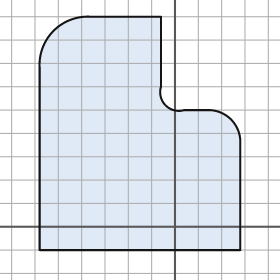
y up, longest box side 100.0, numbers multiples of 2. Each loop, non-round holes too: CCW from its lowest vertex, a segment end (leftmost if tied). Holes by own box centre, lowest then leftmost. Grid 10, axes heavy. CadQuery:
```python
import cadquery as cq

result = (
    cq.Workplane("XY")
    .moveTo(-58.0, -10.0)
    .lineTo(28.0, -10.0)
    .lineTo(28.0, 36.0)
    .threePointArc((24.0, 46.0), (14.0, 50.0))
    .lineTo(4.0, 50.0)
    .threePointArc((-4.0, 52.0), (-6.0, 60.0))
    .lineTo(-6.0, 90.0)
    .lineTo(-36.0, 90.0)
    .threePointArc((-52.0, 84.0), (-58.0, 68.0))
    .close()
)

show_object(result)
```